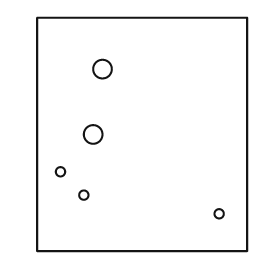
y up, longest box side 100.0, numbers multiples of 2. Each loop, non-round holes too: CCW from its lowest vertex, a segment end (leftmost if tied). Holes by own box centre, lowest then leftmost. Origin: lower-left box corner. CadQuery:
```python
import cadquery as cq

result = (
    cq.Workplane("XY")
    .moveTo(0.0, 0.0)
    .lineTo(90.0, 0.0)
    .lineTo(90.0, 100.0)
    .lineTo(0.0, 100.0)
    .close()
    .moveTo(78.0, 16.0)
    .circle(2.0)
    .moveTo(20.0, 24.0)
    .circle(2.0)
    .moveTo(10.0, 34.0)
    .circle(2.0)
    .moveTo(24.0, 50.0)
    .circle(4.0)
    .moveTo(28.0, 78.0)
    .circle(4.0)
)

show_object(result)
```